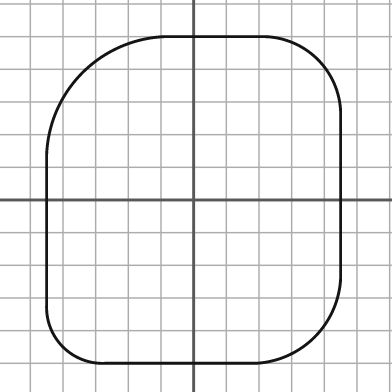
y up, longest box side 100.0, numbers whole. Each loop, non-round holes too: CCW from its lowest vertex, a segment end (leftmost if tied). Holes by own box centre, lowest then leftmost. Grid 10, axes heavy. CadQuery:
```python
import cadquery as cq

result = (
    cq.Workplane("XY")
    .moveTo(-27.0, -50.0)
    .lineTo(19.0, -50.0)
    .threePointArc((37.0, -42.0), (45.0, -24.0))
    .lineTo(45.0, 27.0)
    .threePointArc((38.0, 43.0), (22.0, 50.0))
    .lineTo(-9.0, 50.0)
    .threePointArc((-34.0, 39.0), (-45.0, 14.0))
    .lineTo(-45.0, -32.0)
    .threePointArc((-40.0, -45.0), (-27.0, -50.0))
    .close()
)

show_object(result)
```